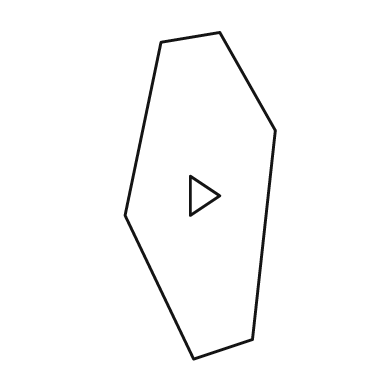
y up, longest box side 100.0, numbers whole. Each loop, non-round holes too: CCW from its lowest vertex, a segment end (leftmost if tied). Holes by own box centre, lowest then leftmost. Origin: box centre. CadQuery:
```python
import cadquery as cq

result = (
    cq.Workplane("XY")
    .moveTo(-2.0, -50.0)
    .lineTo(16.0, -44.0)
    .lineTo(23.0, 20.0)
    .lineTo(6.0, 50.0)
    .lineTo(-12.0, 47.0)
    .lineTo(-23.0, -6.0)
    .close()
    .moveTo(-3.0, -6.0)
    .lineTo(6.0, 0.0)
    .lineTo(-3.0, 6.0)
    .close()
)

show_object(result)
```